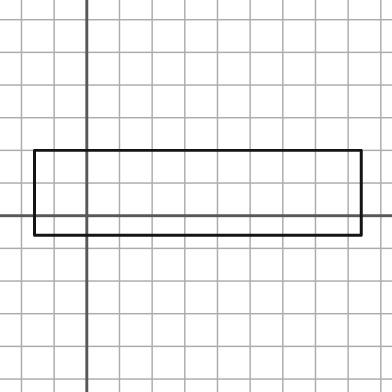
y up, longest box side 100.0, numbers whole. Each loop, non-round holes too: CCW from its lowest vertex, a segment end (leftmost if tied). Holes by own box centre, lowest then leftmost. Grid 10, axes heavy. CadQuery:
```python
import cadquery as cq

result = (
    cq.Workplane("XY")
    .moveTo(-16.0, -6.0)
    .lineTo(84.0, -6.0)
    .lineTo(84.0, 20.0)
    .lineTo(-16.0, 20.0)
    .close()
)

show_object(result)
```